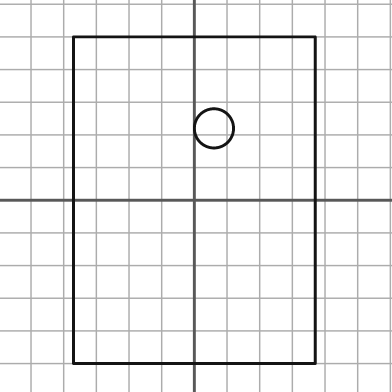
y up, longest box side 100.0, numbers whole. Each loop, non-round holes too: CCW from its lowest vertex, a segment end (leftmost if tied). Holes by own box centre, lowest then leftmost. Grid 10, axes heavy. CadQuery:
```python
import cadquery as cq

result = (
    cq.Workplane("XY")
    .moveTo(-37.0, -50.0)
    .lineTo(37.0, -50.0)
    .lineTo(37.0, 50.0)
    .lineTo(-37.0, 50.0)
    .close()
    .moveTo(6.0, 22.0)
    .circle(6.0)
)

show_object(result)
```